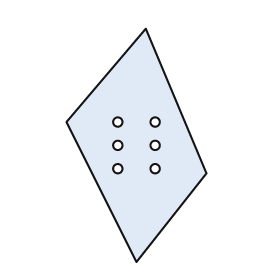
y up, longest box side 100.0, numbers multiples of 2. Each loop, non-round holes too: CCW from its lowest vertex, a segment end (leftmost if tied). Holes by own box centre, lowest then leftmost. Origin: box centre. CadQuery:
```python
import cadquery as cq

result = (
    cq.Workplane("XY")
    .moveTo(0.0, -50.0)
    .lineTo(30.0, -12.0)
    .lineTo(4.0, 50.0)
    .lineTo(-30.0, 10.0)
    .close()
    .moveTo(-8.0, -10.0)
    .circle(2.0)
    .moveTo(8.0, -10.0)
    .circle(2.0)
    .moveTo(-8.0, 0.0)
    .circle(2.0)
    .moveTo(8.0, 0.0)
    .circle(2.0)
    .moveTo(-8.0, 10.0)
    .circle(2.0)
    .moveTo(8.0, 10.0)
    .circle(2.0)
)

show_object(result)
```